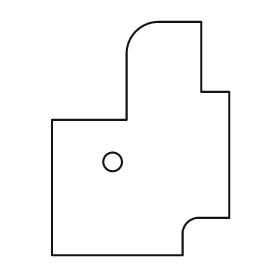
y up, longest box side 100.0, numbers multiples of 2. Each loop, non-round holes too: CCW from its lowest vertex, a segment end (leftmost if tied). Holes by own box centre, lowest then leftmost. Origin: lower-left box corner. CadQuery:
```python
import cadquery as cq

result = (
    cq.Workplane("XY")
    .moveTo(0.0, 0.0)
    .lineTo(56.0, 0.0)
    .lineTo(56.0, 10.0)
    .threePointArc((58.0, 14.0), (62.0, 16.0))
    .lineTo(76.0, 16.0)
    .lineTo(76.0, 70.0)
    .lineTo(64.0, 70.0)
    .lineTo(64.0, 100.0)
    .lineTo(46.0, 100.0)
    .threePointArc((36.0, 96.0), (32.0, 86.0))
    .lineTo(32.0, 58.0)
    .lineTo(0.0, 58.0)
    .close()
    .moveTo(26.0, 40.0)
    .circle(4.0)
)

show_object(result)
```